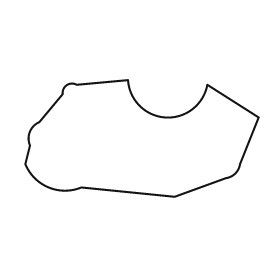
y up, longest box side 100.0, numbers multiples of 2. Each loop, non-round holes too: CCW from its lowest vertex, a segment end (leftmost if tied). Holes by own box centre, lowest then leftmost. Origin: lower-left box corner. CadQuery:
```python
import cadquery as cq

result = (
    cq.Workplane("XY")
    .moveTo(64.0, 0.0)
    .lineTo(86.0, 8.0)
    .threePointArc((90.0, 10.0), (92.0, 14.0))
    .lineTo(100.0, 34.0)
    .lineTo(78.0, 48.0)
    .threePointArc((60.0, 34.0), (44.0, 50.0))
    .lineTo(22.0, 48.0)
    .threePointArc((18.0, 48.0), (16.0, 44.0))
    .lineTo(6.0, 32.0)
    .threePointArc((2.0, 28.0), (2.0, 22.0))
    .lineTo(0.0, 14.0)
    .threePointArc((10.0, 4.0), (24.0, 4.0))
    .close()
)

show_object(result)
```